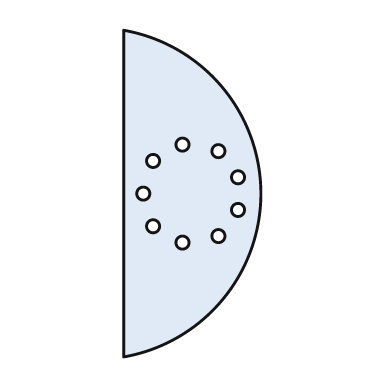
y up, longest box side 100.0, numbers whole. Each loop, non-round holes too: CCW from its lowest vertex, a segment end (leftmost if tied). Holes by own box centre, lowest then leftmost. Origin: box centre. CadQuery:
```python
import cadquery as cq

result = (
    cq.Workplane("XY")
    .moveTo(-21.0, -50.0)
    .threePointArc((21.0, 0.0), (-21.0, 50.0))
    .close()
    .moveTo(-3.0, -15.0)
    .circle(2.0)
    .moveTo(8.0, -13.0)
    .circle(2.0)
    .moveTo(-12.0, -10.0)
    .circle(2.0)
    .moveTo(14.0, -5.0)
    .circle(2.0)
    .moveTo(-15.0, 0.0)
    .circle(2.0)
    .moveTo(14.0, 5.0)
    .circle(2.0)
    .moveTo(-12.0, 10.0)
    .circle(2.0)
    .moveTo(8.0, 13.0)
    .circle(2.0)
    .moveTo(-3.0, 15.0)
    .circle(2.0)
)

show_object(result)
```